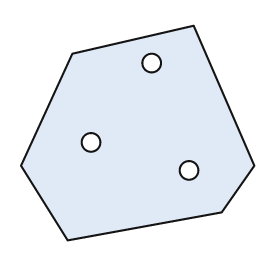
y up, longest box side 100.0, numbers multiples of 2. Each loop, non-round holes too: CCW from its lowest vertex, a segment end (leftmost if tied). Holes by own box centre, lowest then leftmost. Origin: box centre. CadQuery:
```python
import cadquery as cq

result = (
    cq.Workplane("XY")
    .moveTo(-30.0, -46.0)
    .lineTo(36.0, -34.0)
    .lineTo(50.0, -14.0)
    .lineTo(24.0, 46.0)
    .lineTo(-28.0, 34.0)
    .lineTo(-50.0, -14.0)
    .close()
    .moveTo(22.0, -16.0)
    .circle(4.0)
    .moveTo(-20.0, -4.0)
    .circle(4.0)
    .moveTo(6.0, 30.0)
    .circle(4.0)
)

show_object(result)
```